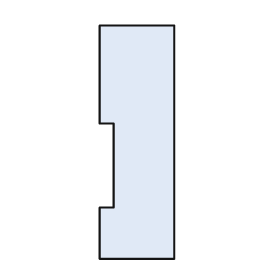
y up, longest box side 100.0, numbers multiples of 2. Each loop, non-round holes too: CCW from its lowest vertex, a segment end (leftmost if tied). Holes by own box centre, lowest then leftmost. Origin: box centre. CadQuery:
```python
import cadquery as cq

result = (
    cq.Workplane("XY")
    .moveTo(-16.0, -50.0)
    .lineTo(16.0, -50.0)
    .lineTo(16.0, 50.0)
    .lineTo(-16.0, 50.0)
    .lineTo(-16.0, 8.0)
    .lineTo(-10.0, 8.0)
    .lineTo(-10.0, -28.0)
    .lineTo(-16.0, -28.0)
    .close()
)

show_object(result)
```